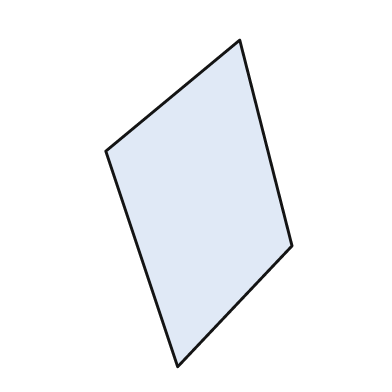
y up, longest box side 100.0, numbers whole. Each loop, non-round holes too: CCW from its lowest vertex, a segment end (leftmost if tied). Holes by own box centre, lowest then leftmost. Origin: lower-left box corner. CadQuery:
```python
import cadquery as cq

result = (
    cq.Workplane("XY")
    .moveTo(22.0, 0.0)
    .lineTo(57.0, 37.0)
    .lineTo(41.0, 100.0)
    .lineTo(0.0, 66.0)
    .close()
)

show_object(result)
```